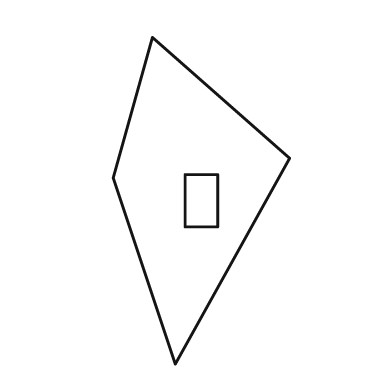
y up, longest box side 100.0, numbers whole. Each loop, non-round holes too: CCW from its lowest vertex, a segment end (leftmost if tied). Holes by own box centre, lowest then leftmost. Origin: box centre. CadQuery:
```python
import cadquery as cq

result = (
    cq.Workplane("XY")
    .moveTo(-8.0, -50.0)
    .lineTo(27.0, 13.0)
    .lineTo(-15.0, 50.0)
    .lineTo(-27.0, 7.0)
    .close()
    .moveTo(-5.0, -8.0)
    .lineTo(5.0, -8.0)
    .lineTo(5.0, 8.0)
    .lineTo(-5.0, 8.0)
    .close()
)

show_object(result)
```